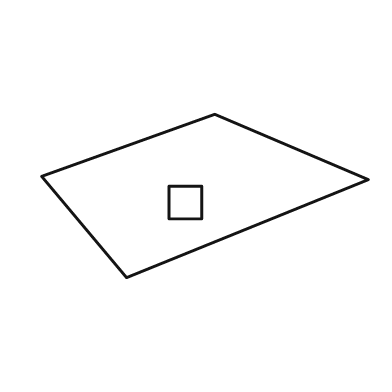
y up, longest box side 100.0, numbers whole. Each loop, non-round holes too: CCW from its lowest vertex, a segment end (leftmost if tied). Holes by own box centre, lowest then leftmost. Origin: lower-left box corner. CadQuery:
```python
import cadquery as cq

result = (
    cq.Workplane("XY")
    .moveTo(26.0, 0.0)
    .lineTo(100.0, 30.0)
    .lineTo(53.0, 50.0)
    .lineTo(0.0, 31.0)
    .close()
    .moveTo(39.0, 18.0)
    .lineTo(49.0, 18.0)
    .lineTo(49.0, 28.0)
    .lineTo(39.0, 28.0)
    .close()
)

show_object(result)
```